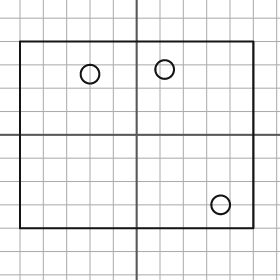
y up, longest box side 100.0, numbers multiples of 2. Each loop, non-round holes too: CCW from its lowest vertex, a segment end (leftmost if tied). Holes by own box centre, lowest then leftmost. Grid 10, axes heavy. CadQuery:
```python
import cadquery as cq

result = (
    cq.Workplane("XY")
    .moveTo(-50.0, -40.0)
    .lineTo(50.0, -40.0)
    .lineTo(50.0, 40.0)
    .lineTo(-50.0, 40.0)
    .close()
    .moveTo(36.0, -30.0)
    .circle(4.0)
    .moveTo(-20.0, 26.0)
    .circle(4.0)
    .moveTo(12.0, 28.0)
    .circle(4.0)
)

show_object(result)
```